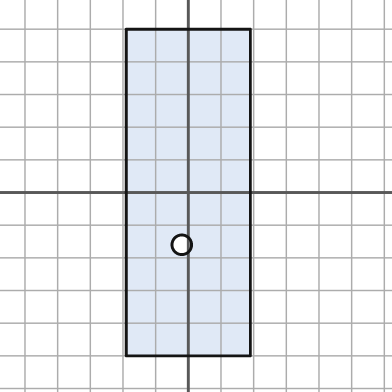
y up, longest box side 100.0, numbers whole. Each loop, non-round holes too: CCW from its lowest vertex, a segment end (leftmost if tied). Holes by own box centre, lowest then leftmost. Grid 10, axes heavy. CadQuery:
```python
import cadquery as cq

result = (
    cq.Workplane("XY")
    .moveTo(-19.0, -50.0)
    .lineTo(19.0, -50.0)
    .lineTo(19.0, 50.0)
    .lineTo(-19.0, 50.0)
    .close()
    .moveTo(-2.0, -16.0)
    .circle(3.0)
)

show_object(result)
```